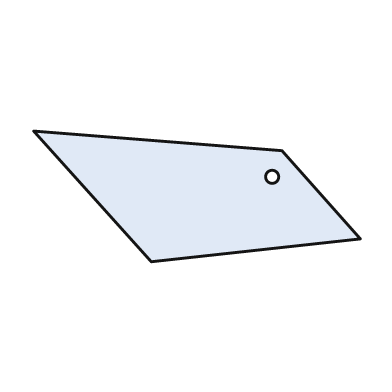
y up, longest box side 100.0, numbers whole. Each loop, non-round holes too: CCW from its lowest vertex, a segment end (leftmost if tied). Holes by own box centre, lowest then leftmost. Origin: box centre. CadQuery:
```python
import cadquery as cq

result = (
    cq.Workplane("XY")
    .moveTo(-14.0, -20.0)
    .lineTo(50.0, -13.0)
    .lineTo(26.0, 14.0)
    .lineTo(-50.0, 20.0)
    .close()
    .moveTo(23.0, 6.0)
    .circle(2.0)
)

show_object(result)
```